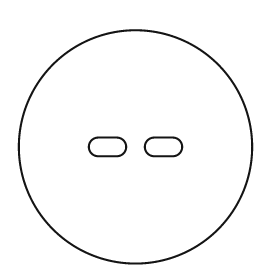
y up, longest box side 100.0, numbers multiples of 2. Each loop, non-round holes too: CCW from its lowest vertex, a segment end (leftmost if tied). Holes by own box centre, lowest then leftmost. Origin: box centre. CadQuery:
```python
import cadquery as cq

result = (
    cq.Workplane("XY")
    .moveTo(0.0, 0.0)
    .circle(50.0)
    .moveTo(-16.0, -4.0)
    .lineTo(-8.0, -4.0)
    .threePointArc((-4.0, 0.0), (-8.0, 4.0))
    .lineTo(-16.0, 4.0)
    .threePointArc((-20.0, 0.0), (-16.0, -4.0))
    .close()
    .moveTo(8.0, -4.0)
    .lineTo(16.0, -4.0)
    .threePointArc((20.0, 0.0), (16.0, 4.0))
    .lineTo(8.0, 4.0)
    .threePointArc((4.0, 0.0), (8.0, -4.0))
    .close()
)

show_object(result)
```